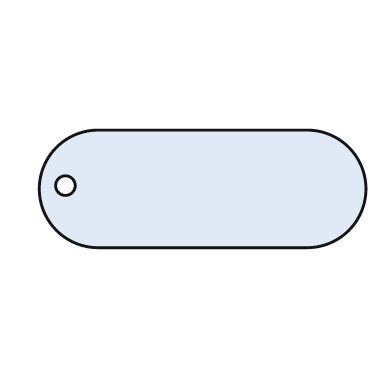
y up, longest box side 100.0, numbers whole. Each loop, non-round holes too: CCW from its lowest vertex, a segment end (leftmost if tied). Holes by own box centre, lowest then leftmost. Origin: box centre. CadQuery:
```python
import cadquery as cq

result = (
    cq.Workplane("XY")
    .moveTo(-32.0, -18.0)
    .lineTo(32.0, -18.0)
    .threePointArc((50.0, 0.0), (32.0, 18.0))
    .lineTo(-32.0, 18.0)
    .threePointArc((-50.0, 0.0), (-32.0, -18.0))
    .close()
    .moveTo(-42.0, 1.0)
    .circle(3.0)
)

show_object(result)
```